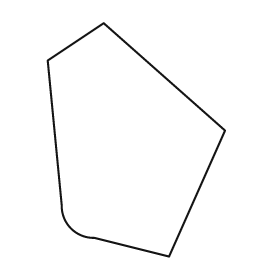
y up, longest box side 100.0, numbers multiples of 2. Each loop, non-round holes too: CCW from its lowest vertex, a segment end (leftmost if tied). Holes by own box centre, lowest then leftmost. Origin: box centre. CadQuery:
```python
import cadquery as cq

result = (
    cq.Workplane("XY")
    .moveTo(14.0, -50.0)
    .lineTo(38.0, 4.0)
    .lineTo(-14.0, 50.0)
    .lineTo(-38.0, 34.0)
    .lineTo(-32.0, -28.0)
    .threePointArc((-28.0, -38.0), (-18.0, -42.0))
    .close()
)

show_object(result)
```